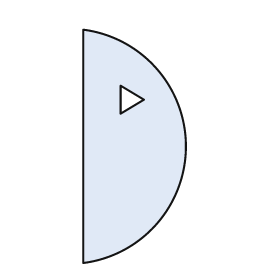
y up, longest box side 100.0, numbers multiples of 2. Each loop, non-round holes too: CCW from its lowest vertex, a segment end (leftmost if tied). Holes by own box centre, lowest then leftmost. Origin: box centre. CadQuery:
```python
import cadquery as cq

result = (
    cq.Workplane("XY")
    .moveTo(-22.0, -50.0)
    .threePointArc((22.0, 0.0), (-22.0, 50.0))
    .close()
    .moveTo(-6.0, 14.0)
    .lineTo(4.0, 20.0)
    .lineTo(-6.0, 26.0)
    .close()
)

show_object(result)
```